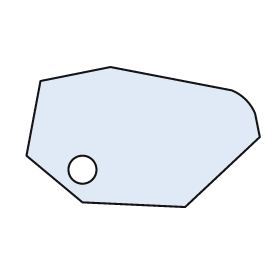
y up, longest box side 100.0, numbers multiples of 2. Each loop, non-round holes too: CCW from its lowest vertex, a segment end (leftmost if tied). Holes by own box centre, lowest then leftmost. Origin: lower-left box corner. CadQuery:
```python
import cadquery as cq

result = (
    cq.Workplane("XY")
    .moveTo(68.0, 0.0)
    .lineTo(100.0, 30.0)
    .lineTo(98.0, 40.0)
    .threePointArc((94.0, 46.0), (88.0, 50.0))
    .lineTo(36.0, 60.0)
    .lineTo(6.0, 54.0)
    .lineTo(0.0, 22.0)
    .lineTo(24.0, 2.0)
    .close()
    .moveTo(24.0, 16.0)
    .circle(6.0)
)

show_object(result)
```